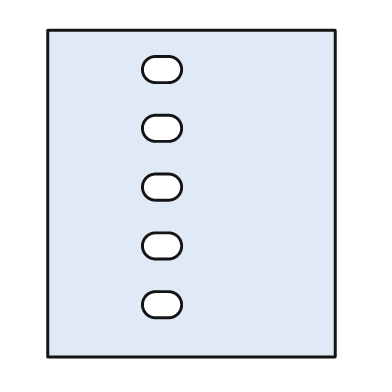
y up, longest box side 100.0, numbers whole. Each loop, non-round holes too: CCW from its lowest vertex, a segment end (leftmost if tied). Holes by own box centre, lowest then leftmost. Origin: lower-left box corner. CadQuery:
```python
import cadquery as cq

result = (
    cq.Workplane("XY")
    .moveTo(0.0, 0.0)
    .lineTo(88.0, 0.0)
    .lineTo(88.0, 100.0)
    .lineTo(0.0, 100.0)
    .close()
    .moveTo(33.0, 12.0)
    .lineTo(37.0, 12.0)
    .threePointArc((41.0, 16.0), (37.0, 20.0))
    .lineTo(33.0, 20.0)
    .threePointArc((29.0, 16.0), (33.0, 12.0))
    .close()
    .moveTo(33.0, 30.0)
    .lineTo(37.0, 30.0)
    .threePointArc((41.0, 34.0), (37.0, 38.0))
    .lineTo(33.0, 38.0)
    .threePointArc((29.0, 34.0), (33.0, 30.0))
    .close()
    .moveTo(33.0, 48.0)
    .lineTo(37.0, 48.0)
    .threePointArc((41.0, 52.0), (37.0, 56.0))
    .lineTo(33.0, 56.0)
    .threePointArc((29.0, 52.0), (33.0, 48.0))
    .close()
    .moveTo(33.0, 66.0)
    .lineTo(37.0, 66.0)
    .threePointArc((41.0, 70.0), (37.0, 74.0))
    .lineTo(33.0, 74.0)
    .threePointArc((29.0, 70.0), (33.0, 66.0))
    .close()
    .moveTo(33.0, 84.0)
    .lineTo(37.0, 84.0)
    .threePointArc((41.0, 88.0), (37.0, 92.0))
    .lineTo(33.0, 92.0)
    .threePointArc((29.0, 88.0), (33.0, 84.0))
    .close()
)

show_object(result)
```